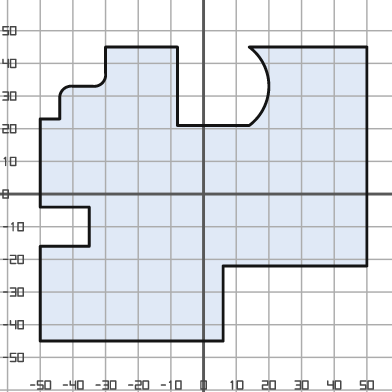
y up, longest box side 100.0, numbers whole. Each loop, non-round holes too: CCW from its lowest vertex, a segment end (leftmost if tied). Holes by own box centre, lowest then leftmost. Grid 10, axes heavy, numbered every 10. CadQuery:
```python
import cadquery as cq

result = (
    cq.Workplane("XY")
    .moveTo(-50.0, -45.0)
    .lineTo(6.0, -45.0)
    .lineTo(6.0, -22.0)
    .lineTo(50.0, -22.0)
    .lineTo(50.0, 45.0)
    .lineTo(14.0, 45.0)
    .threePointArc((20.0, 33.0), (14.0, 21.0))
    .lineTo(-8.0, 21.0)
    .lineTo(-8.0, 45.0)
    .lineTo(-30.0, 45.0)
    .lineTo(-30.0, 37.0)
    .threePointArc((-31.0, 34.0), (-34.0, 33.0))
    .lineTo(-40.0, 33.0)
    .threePointArc((-43.0, 32.0), (-44.0, 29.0))
    .lineTo(-44.0, 23.0)
    .lineTo(-50.0, 23.0)
    .lineTo(-50.0, -4.0)
    .lineTo(-35.0, -4.0)
    .lineTo(-35.0, -16.0)
    .lineTo(-50.0, -16.0)
    .close()
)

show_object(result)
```